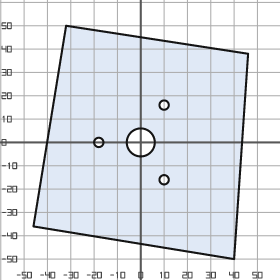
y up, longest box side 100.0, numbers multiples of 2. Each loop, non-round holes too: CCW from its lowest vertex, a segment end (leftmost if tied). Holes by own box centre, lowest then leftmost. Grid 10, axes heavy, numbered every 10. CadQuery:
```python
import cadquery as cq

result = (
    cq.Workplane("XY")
    .moveTo(40.0, -50.0)
    .lineTo(46.0, 38.0)
    .lineTo(-32.0, 50.0)
    .lineTo(-46.0, -36.0)
    .close()
    .moveTo(10.0, -16.0)
    .circle(2.0)
    .moveTo(-18.0, 0.0)
    .circle(2.0)
    .moveTo(0.0, 0.0)
    .circle(6.0)
    .moveTo(10.0, 16.0)
    .circle(2.0)
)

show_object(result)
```